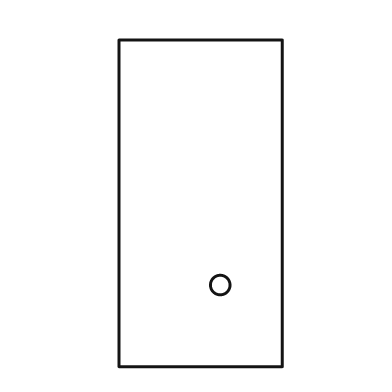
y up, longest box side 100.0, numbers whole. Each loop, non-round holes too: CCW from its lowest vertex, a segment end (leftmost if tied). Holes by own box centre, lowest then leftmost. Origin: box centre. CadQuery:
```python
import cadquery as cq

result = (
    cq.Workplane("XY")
    .moveTo(-25.0, -50.0)
    .lineTo(25.0, -50.0)
    .lineTo(25.0, 50.0)
    .lineTo(-25.0, 50.0)
    .close()
    .moveTo(6.0, -25.0)
    .circle(3.0)
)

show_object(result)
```